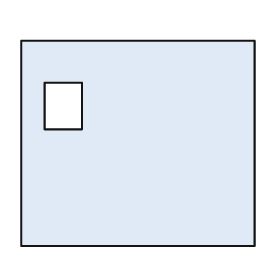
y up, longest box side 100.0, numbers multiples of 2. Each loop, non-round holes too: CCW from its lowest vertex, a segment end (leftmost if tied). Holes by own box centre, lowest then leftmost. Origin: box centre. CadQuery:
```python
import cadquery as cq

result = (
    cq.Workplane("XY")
    .moveTo(-50.0, -44.0)
    .lineTo(50.0, -44.0)
    .lineTo(50.0, 44.0)
    .lineTo(-50.0, 44.0)
    .close()
    .moveTo(-40.0, 6.0)
    .lineTo(-24.0, 6.0)
    .lineTo(-24.0, 26.0)
    .lineTo(-40.0, 26.0)
    .close()
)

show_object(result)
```